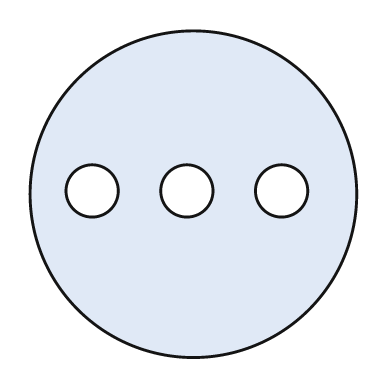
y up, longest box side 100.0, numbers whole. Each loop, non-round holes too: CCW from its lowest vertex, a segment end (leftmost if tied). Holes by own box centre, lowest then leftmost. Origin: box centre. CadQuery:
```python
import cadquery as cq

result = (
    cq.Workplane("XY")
    .moveTo(0.0, 0.0)
    .circle(50.0)
    .moveTo(-31.0, 1.0)
    .circle(8.0)
    .moveTo(-2.0, 1.0)
    .circle(8.0)
    .moveTo(27.0, 1.0)
    .circle(8.0)
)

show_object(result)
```